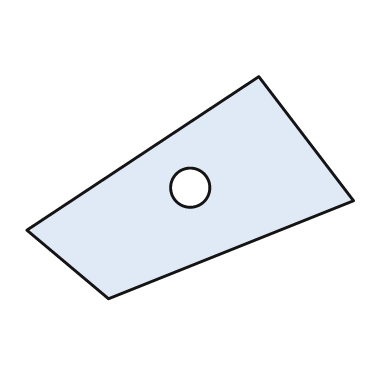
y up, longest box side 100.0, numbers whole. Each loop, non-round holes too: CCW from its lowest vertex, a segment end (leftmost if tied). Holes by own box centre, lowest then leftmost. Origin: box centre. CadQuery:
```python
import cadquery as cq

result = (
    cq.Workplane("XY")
    .moveTo(-25.0, -34.0)
    .lineTo(50.0, -4.0)
    .lineTo(21.0, 34.0)
    .lineTo(-50.0, -13.0)
    .close()
    .moveTo(0.0, 0.0)
    .circle(6.0)
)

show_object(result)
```